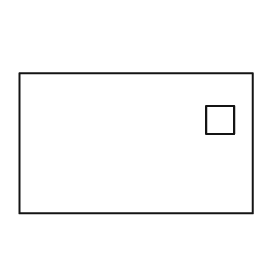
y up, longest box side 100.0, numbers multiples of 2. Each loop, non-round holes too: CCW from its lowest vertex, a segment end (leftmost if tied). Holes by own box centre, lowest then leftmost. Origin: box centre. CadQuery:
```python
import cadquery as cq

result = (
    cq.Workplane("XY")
    .moveTo(-50.0, -30.0)
    .lineTo(50.0, -30.0)
    .lineTo(50.0, 30.0)
    .lineTo(-50.0, 30.0)
    .close()
    .moveTo(30.0, 4.0)
    .lineTo(42.0, 4.0)
    .lineTo(42.0, 16.0)
    .lineTo(30.0, 16.0)
    .close()
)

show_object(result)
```